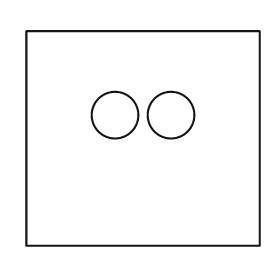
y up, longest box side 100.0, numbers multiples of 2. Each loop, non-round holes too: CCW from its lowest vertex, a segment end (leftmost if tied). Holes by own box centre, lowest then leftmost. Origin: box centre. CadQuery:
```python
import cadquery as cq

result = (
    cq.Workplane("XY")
    .moveTo(-50.0, -46.0)
    .lineTo(50.0, -46.0)
    .lineTo(50.0, 46.0)
    .lineTo(-50.0, 46.0)
    .close()
    .moveTo(-12.0, 10.0)
    .circle(10.0)
    .moveTo(12.0, 10.0)
    .circle(10.0)
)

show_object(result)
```